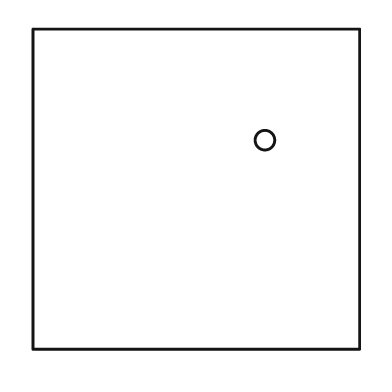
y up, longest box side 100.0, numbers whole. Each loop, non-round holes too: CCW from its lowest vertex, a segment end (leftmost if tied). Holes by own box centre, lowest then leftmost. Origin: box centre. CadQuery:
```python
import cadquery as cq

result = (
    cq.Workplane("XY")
    .moveTo(-50.0, -49.0)
    .lineTo(50.0, -49.0)
    .lineTo(50.0, 49.0)
    .lineTo(-50.0, 49.0)
    .close()
    .moveTo(21.0, 15.0)
    .circle(3.0)
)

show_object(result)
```